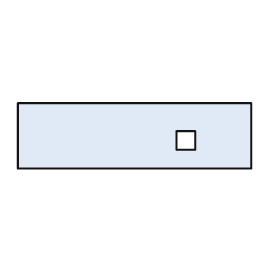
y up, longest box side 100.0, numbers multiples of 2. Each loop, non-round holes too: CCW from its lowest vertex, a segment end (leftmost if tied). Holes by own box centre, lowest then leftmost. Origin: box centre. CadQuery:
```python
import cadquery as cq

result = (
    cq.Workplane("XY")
    .moveTo(-50.0, -14.0)
    .lineTo(50.0, -14.0)
    .lineTo(50.0, 14.0)
    .lineTo(-50.0, 14.0)
    .close()
    .moveTo(18.0, -6.0)
    .lineTo(26.0, -6.0)
    .lineTo(26.0, 2.0)
    .lineTo(18.0, 2.0)
    .close()
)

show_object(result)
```